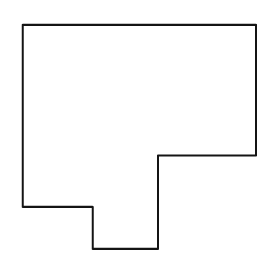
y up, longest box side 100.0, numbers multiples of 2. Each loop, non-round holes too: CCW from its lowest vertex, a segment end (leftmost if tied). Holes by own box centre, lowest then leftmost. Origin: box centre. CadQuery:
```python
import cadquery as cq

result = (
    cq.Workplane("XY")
    .moveTo(-20.0, -48.0)
    .lineTo(8.0, -48.0)
    .lineTo(8.0, -8.0)
    .lineTo(50.0, -8.0)
    .lineTo(50.0, 48.0)
    .lineTo(-50.0, 48.0)
    .lineTo(-50.0, -30.0)
    .lineTo(-20.0, -30.0)
    .close()
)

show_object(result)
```